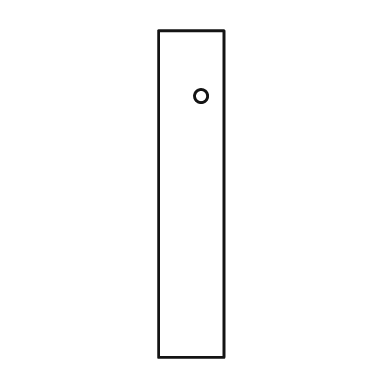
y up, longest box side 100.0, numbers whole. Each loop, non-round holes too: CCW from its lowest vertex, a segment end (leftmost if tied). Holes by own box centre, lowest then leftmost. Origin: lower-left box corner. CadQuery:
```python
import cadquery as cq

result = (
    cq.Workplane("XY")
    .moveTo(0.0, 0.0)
    .lineTo(20.0, 0.0)
    .lineTo(20.0, 100.0)
    .lineTo(0.0, 100.0)
    .close()
    .moveTo(13.0, 80.0)
    .circle(2.0)
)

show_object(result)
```